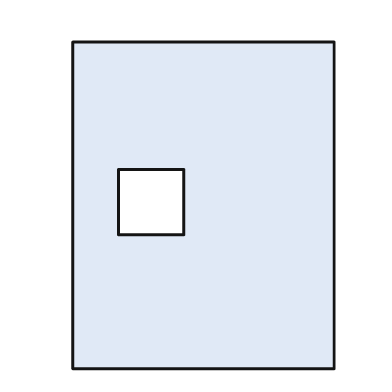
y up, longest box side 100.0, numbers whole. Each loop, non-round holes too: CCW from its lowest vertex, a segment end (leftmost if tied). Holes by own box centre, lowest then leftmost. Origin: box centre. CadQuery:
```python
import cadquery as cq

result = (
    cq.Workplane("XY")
    .moveTo(-40.0, -50.0)
    .lineTo(40.0, -50.0)
    .lineTo(40.0, 50.0)
    .lineTo(-40.0, 50.0)
    .close()
    .moveTo(-26.0, -9.0)
    .lineTo(-6.0, -9.0)
    .lineTo(-6.0, 11.0)
    .lineTo(-26.0, 11.0)
    .close()
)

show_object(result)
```